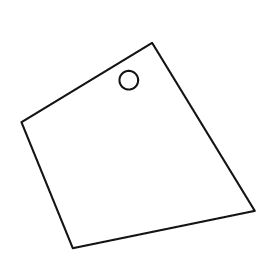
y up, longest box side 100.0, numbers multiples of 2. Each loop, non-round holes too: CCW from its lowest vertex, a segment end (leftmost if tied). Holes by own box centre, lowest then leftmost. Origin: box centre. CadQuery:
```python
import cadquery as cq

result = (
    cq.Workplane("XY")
    .moveTo(-28.0, -44.0)
    .lineTo(50.0, -28.0)
    .lineTo(6.0, 44.0)
    .lineTo(-50.0, 10.0)
    .close()
    .moveTo(-4.0, 28.0)
    .circle(4.0)
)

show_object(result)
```